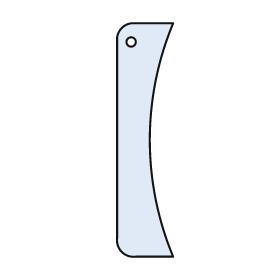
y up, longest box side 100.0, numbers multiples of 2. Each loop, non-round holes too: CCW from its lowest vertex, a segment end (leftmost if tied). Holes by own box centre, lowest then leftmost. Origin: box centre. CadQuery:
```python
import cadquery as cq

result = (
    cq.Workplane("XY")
    .moveTo(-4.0, -50.0)
    .lineTo(12.0, -50.0)
    .threePointArc((2.0, 0.0), (12.0, 50.0))
    .lineTo(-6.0, 50.0)
    .threePointArc((-10.0, 48.0), (-12.0, 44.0))
    .lineTo(-12.0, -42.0)
    .threePointArc((-10.0, -48.0), (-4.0, -50.0))
    .close()
    .moveTo(-6.0, 42.0)
    .circle(2.0)
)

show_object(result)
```